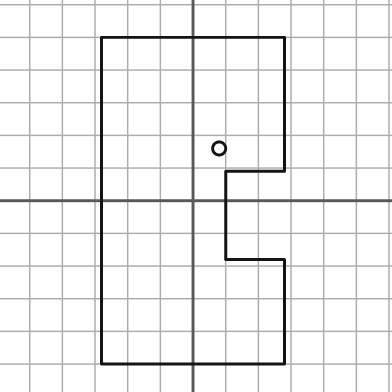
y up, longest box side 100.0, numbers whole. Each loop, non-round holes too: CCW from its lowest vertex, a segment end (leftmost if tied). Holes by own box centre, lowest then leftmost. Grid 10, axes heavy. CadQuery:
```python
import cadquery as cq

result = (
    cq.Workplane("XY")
    .moveTo(-28.0, -50.0)
    .lineTo(28.0, -50.0)
    .lineTo(28.0, -18.0)
    .lineTo(10.0, -18.0)
    .lineTo(10.0, 9.0)
    .lineTo(28.0, 9.0)
    .lineTo(28.0, 50.0)
    .lineTo(-28.0, 50.0)
    .close()
    .moveTo(8.0, 16.0)
    .circle(2.0)
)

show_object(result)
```